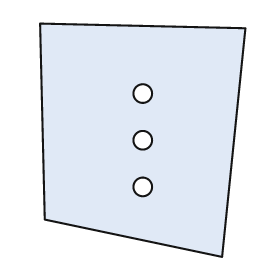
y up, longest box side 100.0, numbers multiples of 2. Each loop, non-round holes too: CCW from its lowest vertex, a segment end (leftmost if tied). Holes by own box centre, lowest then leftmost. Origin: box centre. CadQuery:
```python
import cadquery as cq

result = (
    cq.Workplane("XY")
    .moveTo(34.0, -50.0)
    .lineTo(44.0, 48.0)
    .lineTo(-44.0, 50.0)
    .lineTo(-42.0, -34.0)
    .close()
    .moveTo(0.0, -20.0)
    .circle(4.0)
    .moveTo(0.0, 0.0)
    .circle(4.0)
    .moveTo(0.0, 20.0)
    .circle(4.0)
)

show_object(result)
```